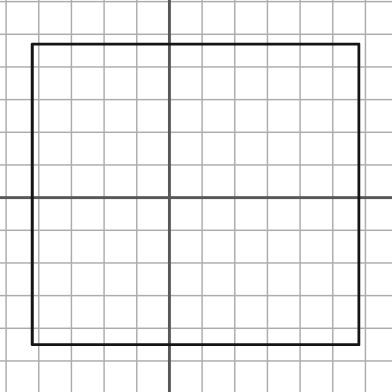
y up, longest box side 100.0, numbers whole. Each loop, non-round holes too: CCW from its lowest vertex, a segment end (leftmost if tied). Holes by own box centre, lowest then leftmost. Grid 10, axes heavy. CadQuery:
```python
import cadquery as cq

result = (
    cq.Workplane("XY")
    .moveTo(-42.0, -45.0)
    .lineTo(58.0, -45.0)
    .lineTo(58.0, 47.0)
    .lineTo(-42.0, 47.0)
    .close()
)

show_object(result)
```